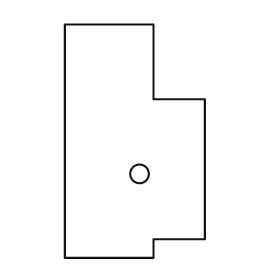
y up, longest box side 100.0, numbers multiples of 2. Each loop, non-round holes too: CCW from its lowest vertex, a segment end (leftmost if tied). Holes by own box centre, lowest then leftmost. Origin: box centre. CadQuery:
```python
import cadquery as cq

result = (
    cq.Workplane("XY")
    .moveTo(-30.0, -50.0)
    .lineTo(8.0, -50.0)
    .lineTo(8.0, -42.0)
    .lineTo(30.0, -42.0)
    .lineTo(30.0, 18.0)
    .lineTo(8.0, 18.0)
    .lineTo(8.0, 50.0)
    .lineTo(-30.0, 50.0)
    .close()
    .moveTo(2.0, -14.0)
    .circle(4.0)
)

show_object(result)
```